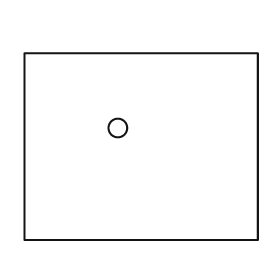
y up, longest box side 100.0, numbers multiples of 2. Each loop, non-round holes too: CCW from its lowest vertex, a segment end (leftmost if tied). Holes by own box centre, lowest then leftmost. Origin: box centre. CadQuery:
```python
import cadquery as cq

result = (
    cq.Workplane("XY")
    .moveTo(-50.0, -40.0)
    .lineTo(50.0, -40.0)
    .lineTo(50.0, 40.0)
    .lineTo(-50.0, 40.0)
    .close()
    .moveTo(-10.0, 8.0)
    .circle(4.0)
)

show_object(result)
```